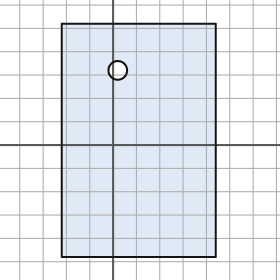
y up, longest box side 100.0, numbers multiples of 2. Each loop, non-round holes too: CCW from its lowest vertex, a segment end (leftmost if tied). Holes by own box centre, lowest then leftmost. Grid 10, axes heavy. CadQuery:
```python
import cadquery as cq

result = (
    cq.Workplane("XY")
    .moveTo(-22.0, -48.0)
    .lineTo(44.0, -48.0)
    .lineTo(44.0, 52.0)
    .lineTo(-22.0, 52.0)
    .close()
    .moveTo(2.0, 32.0)
    .circle(4.0)
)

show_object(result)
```